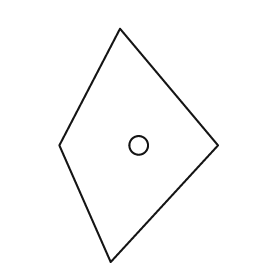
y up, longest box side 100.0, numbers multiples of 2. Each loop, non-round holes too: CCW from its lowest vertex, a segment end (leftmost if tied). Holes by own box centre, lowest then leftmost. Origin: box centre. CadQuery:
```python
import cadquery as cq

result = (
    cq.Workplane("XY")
    .moveTo(-12.0, -50.0)
    .lineTo(34.0, 0.0)
    .lineTo(-8.0, 50.0)
    .lineTo(-34.0, 0.0)
    .close()
    .moveTo(0.0, 0.0)
    .circle(4.0)
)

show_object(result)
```